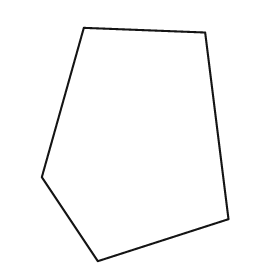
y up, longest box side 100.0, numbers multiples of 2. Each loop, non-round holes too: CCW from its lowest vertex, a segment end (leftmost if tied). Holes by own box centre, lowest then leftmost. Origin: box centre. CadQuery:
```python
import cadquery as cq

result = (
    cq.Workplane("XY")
    .moveTo(-16.0, -50.0)
    .lineTo(40.0, -32.0)
    .lineTo(30.0, 48.0)
    .lineTo(-22.0, 50.0)
    .lineTo(-40.0, -14.0)
    .close()
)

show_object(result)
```